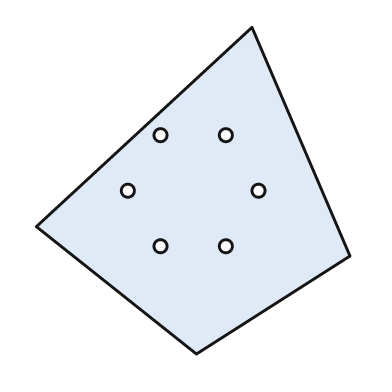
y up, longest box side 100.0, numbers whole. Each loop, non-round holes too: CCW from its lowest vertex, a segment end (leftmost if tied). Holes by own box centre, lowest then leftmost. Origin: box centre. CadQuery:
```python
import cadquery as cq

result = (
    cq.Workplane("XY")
    .moveTo(1.0, -50.0)
    .lineTo(48.0, -20.0)
    .lineTo(18.0, 50.0)
    .lineTo(-48.0, -11.0)
    .close()
    .moveTo(-10.0, -17.0)
    .circle(2.0)
    .moveTo(10.0, -17.0)
    .circle(2.0)
    .moveTo(-20.0, 0.0)
    .circle(2.0)
    .moveTo(20.0, 0.0)
    .circle(2.0)
    .moveTo(-10.0, 17.0)
    .circle(2.0)
    .moveTo(10.0, 17.0)
    .circle(2.0)
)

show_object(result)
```